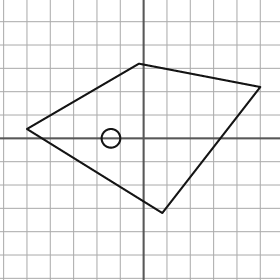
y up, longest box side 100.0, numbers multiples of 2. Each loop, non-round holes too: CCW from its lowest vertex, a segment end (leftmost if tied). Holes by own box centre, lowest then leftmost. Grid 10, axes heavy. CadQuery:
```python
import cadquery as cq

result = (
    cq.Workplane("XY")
    .moveTo(8.0, -32.0)
    .lineTo(50.0, 22.0)
    .lineTo(-2.0, 32.0)
    .lineTo(-50.0, 4.0)
    .close()
    .moveTo(-14.0, 0.0)
    .circle(4.0)
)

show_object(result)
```